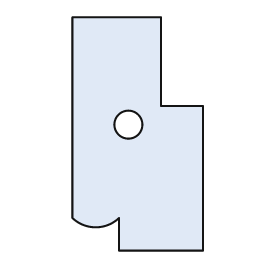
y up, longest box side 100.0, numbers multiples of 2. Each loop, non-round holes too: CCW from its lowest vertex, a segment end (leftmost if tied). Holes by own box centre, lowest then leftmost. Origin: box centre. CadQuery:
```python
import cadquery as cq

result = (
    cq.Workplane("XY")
    .moveTo(-8.0, -50.0)
    .lineTo(28.0, -50.0)
    .lineTo(28.0, 12.0)
    .lineTo(10.0, 12.0)
    .lineTo(10.0, 50.0)
    .lineTo(-28.0, 50.0)
    .lineTo(-28.0, -36.0)
    .threePointArc((-18.0, -40.0), (-8.0, -36.0))
    .close()
    .moveTo(-4.0, 4.0)
    .circle(6.0)
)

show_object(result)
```